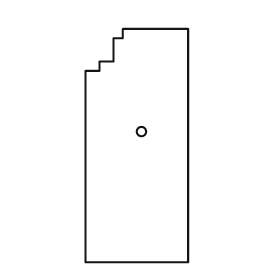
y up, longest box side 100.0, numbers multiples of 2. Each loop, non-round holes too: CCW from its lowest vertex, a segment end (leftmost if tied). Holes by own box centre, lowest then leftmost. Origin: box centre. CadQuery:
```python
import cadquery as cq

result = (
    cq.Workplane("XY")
    .moveTo(-22.0, -50.0)
    .lineTo(22.0, -50.0)
    .lineTo(22.0, 50.0)
    .lineTo(-6.0, 50.0)
    .lineTo(-6.0, 46.0)
    .lineTo(-10.0, 46.0)
    .lineTo(-10.0, 36.0)
    .lineTo(-16.0, 36.0)
    .lineTo(-16.0, 32.0)
    .lineTo(-22.0, 32.0)
    .close()
    .moveTo(2.0, 6.0)
    .circle(2.0)
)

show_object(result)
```